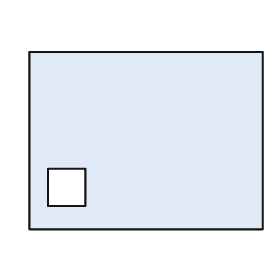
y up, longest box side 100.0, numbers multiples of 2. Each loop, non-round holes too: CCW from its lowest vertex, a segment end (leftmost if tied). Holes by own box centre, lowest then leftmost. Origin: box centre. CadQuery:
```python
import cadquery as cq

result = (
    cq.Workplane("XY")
    .moveTo(-50.0, -38.0)
    .lineTo(50.0, -38.0)
    .lineTo(50.0, 38.0)
    .lineTo(-50.0, 38.0)
    .close()
    .moveTo(-42.0, -28.0)
    .lineTo(-26.0, -28.0)
    .lineTo(-26.0, -12.0)
    .lineTo(-42.0, -12.0)
    .close()
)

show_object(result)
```